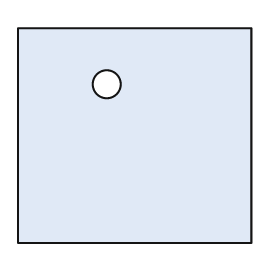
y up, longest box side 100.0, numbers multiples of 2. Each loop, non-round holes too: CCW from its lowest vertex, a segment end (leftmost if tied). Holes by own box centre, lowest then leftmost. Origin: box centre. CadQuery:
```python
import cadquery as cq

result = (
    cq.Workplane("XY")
    .moveTo(-50.0, -46.0)
    .lineTo(50.0, -46.0)
    .lineTo(50.0, 46.0)
    .lineTo(-50.0, 46.0)
    .close()
    .moveTo(-12.0, 22.0)
    .circle(6.0)
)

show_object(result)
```